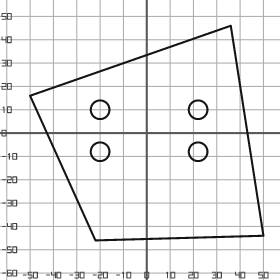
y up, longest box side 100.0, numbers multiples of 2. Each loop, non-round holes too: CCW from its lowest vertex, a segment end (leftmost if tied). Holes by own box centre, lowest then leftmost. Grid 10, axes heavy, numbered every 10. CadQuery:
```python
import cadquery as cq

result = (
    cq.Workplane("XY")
    .moveTo(-22.0, -46.0)
    .lineTo(50.0, -44.0)
    .lineTo(36.0, 46.0)
    .lineTo(-50.0, 16.0)
    .close()
    .moveTo(-20.0, -8.0)
    .circle(4.0)
    .moveTo(22.0, -8.0)
    .circle(4.0)
    .moveTo(-20.0, 10.0)
    .circle(4.0)
    .moveTo(22.0, 10.0)
    .circle(4.0)
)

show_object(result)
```